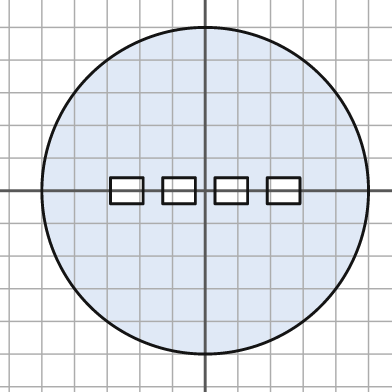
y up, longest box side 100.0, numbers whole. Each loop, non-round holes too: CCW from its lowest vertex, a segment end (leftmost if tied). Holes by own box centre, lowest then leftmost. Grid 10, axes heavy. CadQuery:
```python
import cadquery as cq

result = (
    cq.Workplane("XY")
    .moveTo(0.0, 0.0)
    .circle(50.0)
    .moveTo(-29.0, -4.0)
    .lineTo(-19.0, -4.0)
    .lineTo(-19.0, 4.0)
    .lineTo(-29.0, 4.0)
    .close()
    .moveTo(-13.0, -4.0)
    .lineTo(-3.0, -4.0)
    .lineTo(-3.0, 4.0)
    .lineTo(-13.0, 4.0)
    .close()
    .moveTo(3.0, -4.0)
    .lineTo(13.0, -4.0)
    .lineTo(13.0, 4.0)
    .lineTo(3.0, 4.0)
    .close()
    .moveTo(19.0, -4.0)
    .lineTo(29.0, -4.0)
    .lineTo(29.0, 4.0)
    .lineTo(19.0, 4.0)
    .close()
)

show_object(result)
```